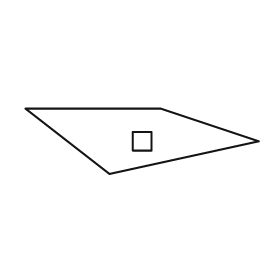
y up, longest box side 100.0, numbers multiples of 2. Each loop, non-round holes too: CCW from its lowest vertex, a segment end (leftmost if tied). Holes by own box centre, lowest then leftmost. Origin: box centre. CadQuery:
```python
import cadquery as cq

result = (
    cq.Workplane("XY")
    .moveTo(-14.0, -14.0)
    .lineTo(50.0, 0.0)
    .lineTo(8.0, 14.0)
    .lineTo(-50.0, 14.0)
    .close()
    .moveTo(-4.0, -4.0)
    .lineTo(4.0, -4.0)
    .lineTo(4.0, 4.0)
    .lineTo(-4.0, 4.0)
    .close()
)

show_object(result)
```